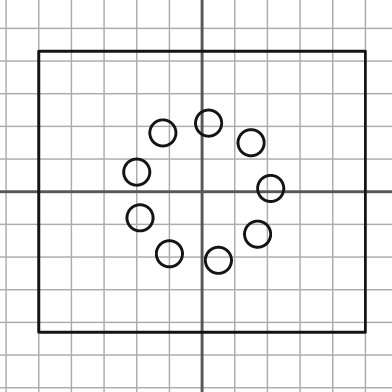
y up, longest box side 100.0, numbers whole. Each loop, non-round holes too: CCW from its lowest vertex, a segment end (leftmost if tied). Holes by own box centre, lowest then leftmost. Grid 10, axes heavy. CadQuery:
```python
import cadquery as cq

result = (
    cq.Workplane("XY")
    .moveTo(-50.0, -43.0)
    .lineTo(50.0, -43.0)
    .lineTo(50.0, 43.0)
    .lineTo(-50.0, 43.0)
    .close()
    .moveTo(5.0, -21.0)
    .circle(4.0)
    .moveTo(-10.0, -19.0)
    .circle(4.0)
    .moveTo(17.0, -13.0)
    .circle(4.0)
    .moveTo(-19.0, -8.0)
    .circle(4.0)
    .moveTo(21.0, 1.0)
    .circle(4.0)
    .moveTo(-20.0, 6.0)
    .circle(4.0)
    .moveTo(15.0, 15.0)
    .circle(4.0)
    .moveTo(-12.0, 18.0)
    .circle(4.0)
    .moveTo(2.0, 21.0)
    .circle(4.0)
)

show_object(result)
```